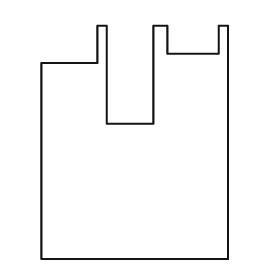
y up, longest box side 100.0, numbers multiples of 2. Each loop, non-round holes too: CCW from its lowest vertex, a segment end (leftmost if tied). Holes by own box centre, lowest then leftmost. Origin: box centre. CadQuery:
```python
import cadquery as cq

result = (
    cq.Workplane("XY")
    .moveTo(-40.0, -50.0)
    .lineTo(40.0, -50.0)
    .lineTo(40.0, 50.0)
    .lineTo(36.0, 50.0)
    .lineTo(36.0, 38.0)
    .lineTo(14.0, 38.0)
    .lineTo(14.0, 50.0)
    .lineTo(8.0, 50.0)
    .lineTo(8.0, 8.0)
    .lineTo(-12.0, 8.0)
    .lineTo(-12.0, 50.0)
    .lineTo(-16.0, 50.0)
    .lineTo(-16.0, 34.0)
    .lineTo(-40.0, 34.0)
    .close()
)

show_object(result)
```